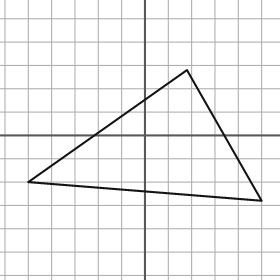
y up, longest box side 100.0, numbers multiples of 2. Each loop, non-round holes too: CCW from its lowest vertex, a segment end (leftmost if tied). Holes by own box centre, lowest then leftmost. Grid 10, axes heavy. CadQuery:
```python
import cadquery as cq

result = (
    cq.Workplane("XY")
    .moveTo(50.0, -28.0)
    .lineTo(18.0, 28.0)
    .lineTo(-50.0, -20.0)
    .close()
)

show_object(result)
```